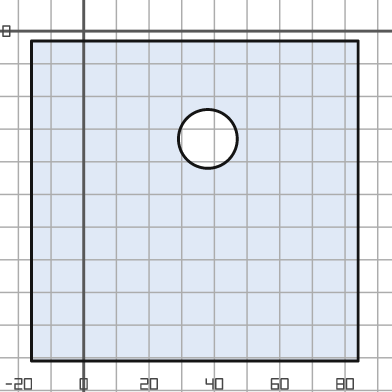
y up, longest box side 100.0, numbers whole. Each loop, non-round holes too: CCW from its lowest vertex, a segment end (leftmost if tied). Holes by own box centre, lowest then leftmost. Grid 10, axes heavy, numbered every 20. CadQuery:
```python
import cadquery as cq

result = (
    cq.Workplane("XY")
    .moveTo(-16.0, -101.0)
    .lineTo(84.0, -101.0)
    .lineTo(84.0, -3.0)
    .lineTo(-16.0, -3.0)
    .close()
    .moveTo(38.0, -33.0)
    .circle(9.0)
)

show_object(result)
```